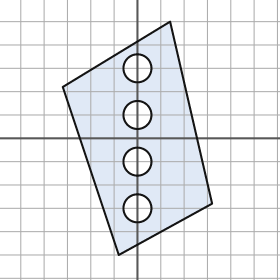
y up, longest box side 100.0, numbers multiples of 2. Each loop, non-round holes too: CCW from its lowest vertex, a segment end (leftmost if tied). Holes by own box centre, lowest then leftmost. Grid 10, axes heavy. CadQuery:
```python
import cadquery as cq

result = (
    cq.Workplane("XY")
    .moveTo(-8.0, -50.0)
    .lineTo(32.0, -28.0)
    .lineTo(14.0, 50.0)
    .lineTo(-32.0, 22.0)
    .close()
    .moveTo(0.0, -30.0)
    .circle(6.0)
    .moveTo(0.0, -10.0)
    .circle(6.0)
    .moveTo(0.0, 10.0)
    .circle(6.0)
    .moveTo(0.0, 30.0)
    .circle(6.0)
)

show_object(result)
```